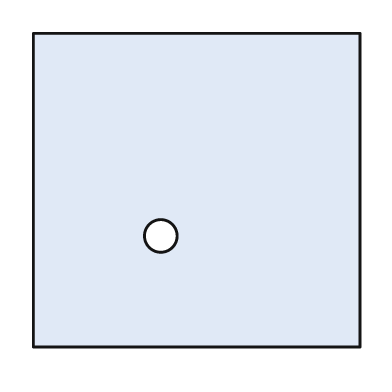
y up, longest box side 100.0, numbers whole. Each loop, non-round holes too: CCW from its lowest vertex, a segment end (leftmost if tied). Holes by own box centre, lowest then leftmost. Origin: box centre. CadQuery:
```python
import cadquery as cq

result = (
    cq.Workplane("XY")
    .moveTo(-50.0, -48.0)
    .lineTo(50.0, -48.0)
    .lineTo(50.0, 48.0)
    .lineTo(-50.0, 48.0)
    .close()
    .moveTo(-11.0, -14.0)
    .circle(5.0)
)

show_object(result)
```